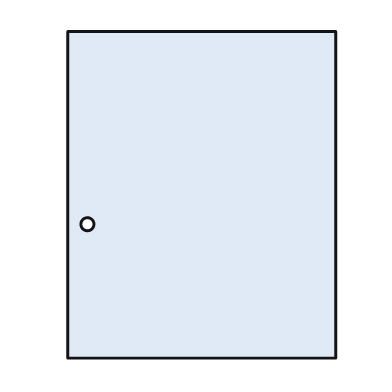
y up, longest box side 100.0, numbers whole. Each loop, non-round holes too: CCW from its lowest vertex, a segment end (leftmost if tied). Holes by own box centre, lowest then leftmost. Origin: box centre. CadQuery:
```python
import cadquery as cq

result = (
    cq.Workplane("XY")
    .moveTo(-41.0, -50.0)
    .lineTo(41.0, -50.0)
    .lineTo(41.0, 50.0)
    .lineTo(-41.0, 50.0)
    .close()
    .moveTo(-35.0, -9.0)
    .circle(2.0)
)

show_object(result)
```